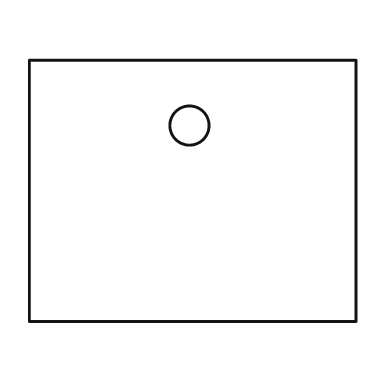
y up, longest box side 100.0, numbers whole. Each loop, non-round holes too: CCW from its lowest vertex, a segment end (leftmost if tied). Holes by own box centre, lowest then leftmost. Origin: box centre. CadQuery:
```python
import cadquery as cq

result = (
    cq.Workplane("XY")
    .moveTo(-50.0, -40.0)
    .lineTo(50.0, -40.0)
    .lineTo(50.0, 40.0)
    .lineTo(-50.0, 40.0)
    .close()
    .moveTo(-1.0, 20.0)
    .circle(6.0)
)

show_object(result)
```